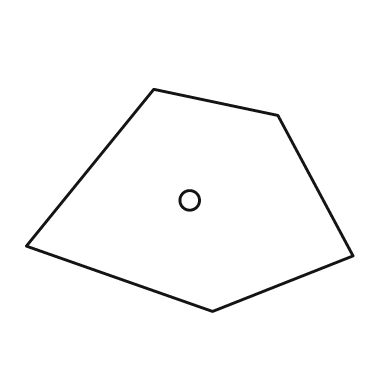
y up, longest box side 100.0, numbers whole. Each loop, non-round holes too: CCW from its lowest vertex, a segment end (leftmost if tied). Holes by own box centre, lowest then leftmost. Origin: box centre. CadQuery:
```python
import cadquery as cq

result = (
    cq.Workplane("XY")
    .moveTo(7.0, -34.0)
    .lineTo(50.0, -17.0)
    .lineTo(27.0, 26.0)
    .lineTo(-11.0, 34.0)
    .lineTo(-50.0, -14.0)
    .close()
    .moveTo(0.0, 0.0)
    .circle(3.0)
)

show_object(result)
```